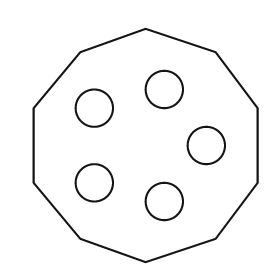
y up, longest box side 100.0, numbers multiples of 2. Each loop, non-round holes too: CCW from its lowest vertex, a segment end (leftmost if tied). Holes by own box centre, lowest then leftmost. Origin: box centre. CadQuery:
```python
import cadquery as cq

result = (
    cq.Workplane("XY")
    .moveTo(0.0, -50.0)
    .lineTo(30.0, -40.0)
    .lineTo(48.0, -16.0)
    .lineTo(48.0, 16.0)
    .lineTo(30.0, 40.0)
    .lineTo(0.0, 50.0)
    .lineTo(-28.0, 40.0)
    .lineTo(-48.0, 16.0)
    .lineTo(-48.0, -16.0)
    .lineTo(-28.0, -40.0)
    .close()
    .moveTo(8.0, -24.0)
    .circle(8.0)
    .moveTo(-22.0, -16.0)
    .circle(8.0)
    .moveTo(26.0, 0.0)
    .circle(8.0)
    .moveTo(-22.0, 16.0)
    .circle(8.0)
    .moveTo(8.0, 24.0)
    .circle(8.0)
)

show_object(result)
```